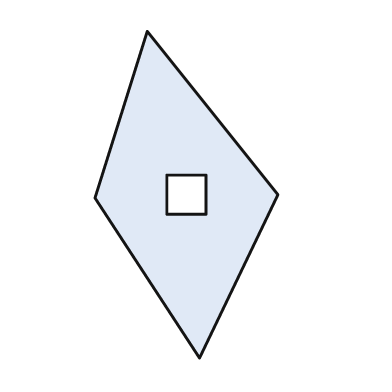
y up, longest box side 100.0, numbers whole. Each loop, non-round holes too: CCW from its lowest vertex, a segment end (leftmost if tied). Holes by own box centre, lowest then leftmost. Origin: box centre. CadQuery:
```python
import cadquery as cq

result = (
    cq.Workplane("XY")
    .moveTo(4.0, -50.0)
    .lineTo(28.0, 0.0)
    .lineTo(-12.0, 50.0)
    .lineTo(-28.0, -1.0)
    .close()
    .moveTo(-6.0, -6.0)
    .lineTo(6.0, -6.0)
    .lineTo(6.0, 6.0)
    .lineTo(-6.0, 6.0)
    .close()
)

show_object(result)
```